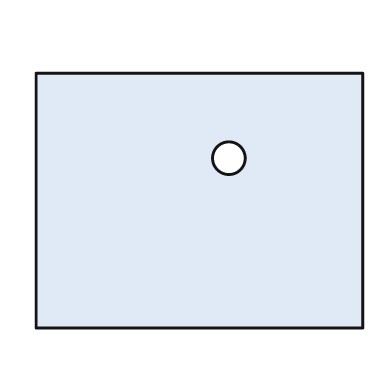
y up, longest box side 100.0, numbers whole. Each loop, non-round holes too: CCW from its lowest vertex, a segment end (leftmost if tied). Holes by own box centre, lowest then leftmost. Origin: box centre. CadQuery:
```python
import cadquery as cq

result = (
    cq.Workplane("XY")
    .moveTo(-50.0, -39.0)
    .lineTo(50.0, -39.0)
    .lineTo(50.0, 39.0)
    .lineTo(-50.0, 39.0)
    .close()
    .moveTo(9.0, 13.0)
    .circle(5.0)
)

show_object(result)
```